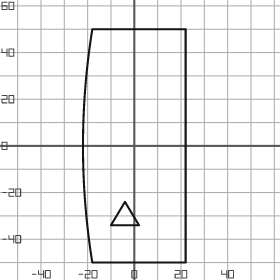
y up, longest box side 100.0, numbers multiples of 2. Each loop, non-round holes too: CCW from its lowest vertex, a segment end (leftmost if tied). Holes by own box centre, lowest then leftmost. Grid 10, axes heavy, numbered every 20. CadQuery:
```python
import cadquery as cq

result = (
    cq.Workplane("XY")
    .moveTo(-18.0, -50.0)
    .lineTo(22.0, -50.0)
    .lineTo(22.0, 50.0)
    .lineTo(-18.0, 50.0)
    .threePointArc((-22.0, 0.0), (-18.0, -50.0))
    .close()
    .moveTo(-10.0, -34.0)
    .lineTo(2.0, -34.0)
    .lineTo(-4.0, -24.0)
    .close()
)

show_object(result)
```